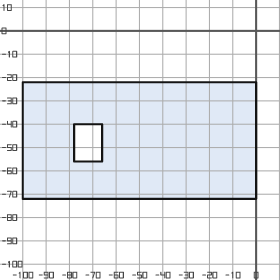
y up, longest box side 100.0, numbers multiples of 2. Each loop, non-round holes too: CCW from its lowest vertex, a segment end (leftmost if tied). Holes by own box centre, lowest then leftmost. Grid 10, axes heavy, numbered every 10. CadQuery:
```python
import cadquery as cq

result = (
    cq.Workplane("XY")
    .moveTo(-100.0, -72.0)
    .lineTo(0.0, -72.0)
    .lineTo(0.0, -22.0)
    .lineTo(-100.0, -22.0)
    .close()
    .moveTo(-78.0, -56.0)
    .lineTo(-66.0, -56.0)
    .lineTo(-66.0, -40.0)
    .lineTo(-78.0, -40.0)
    .close()
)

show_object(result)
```